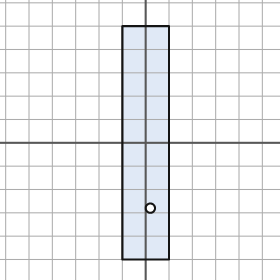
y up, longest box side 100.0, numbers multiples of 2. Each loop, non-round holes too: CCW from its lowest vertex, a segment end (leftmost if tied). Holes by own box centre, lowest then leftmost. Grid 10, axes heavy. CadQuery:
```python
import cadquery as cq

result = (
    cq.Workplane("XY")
    .moveTo(-10.0, -50.0)
    .lineTo(10.0, -50.0)
    .lineTo(10.0, 50.0)
    .lineTo(-10.0, 50.0)
    .close()
    .moveTo(2.0, -28.0)
    .circle(2.0)
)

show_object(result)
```